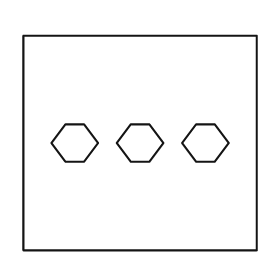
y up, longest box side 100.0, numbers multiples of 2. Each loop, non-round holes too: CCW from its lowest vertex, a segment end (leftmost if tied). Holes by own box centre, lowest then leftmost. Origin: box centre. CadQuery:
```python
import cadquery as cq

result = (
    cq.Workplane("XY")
    .moveTo(-50.0, -46.0)
    .lineTo(50.0, -46.0)
    .lineTo(50.0, 46.0)
    .lineTo(-50.0, 46.0)
    .close()
    .moveTo(-32.0, -8.0)
    .lineTo(-24.0, -8.0)
    .lineTo(-18.0, 0.0)
    .lineTo(-24.0, 8.0)
    .lineTo(-32.0, 8.0)
    .lineTo(-38.0, 0.0)
    .close()
    .moveTo(-4.0, -8.0)
    .lineTo(4.0, -8.0)
    .lineTo(10.0, 0.0)
    .lineTo(4.0, 8.0)
    .lineTo(-4.0, 8.0)
    .lineTo(-10.0, 0.0)
    .close()
    .moveTo(24.0, -8.0)
    .lineTo(32.0, -8.0)
    .lineTo(38.0, 0.0)
    .lineTo(32.0, 8.0)
    .lineTo(24.0, 8.0)
    .lineTo(18.0, 0.0)
    .close()
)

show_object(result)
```